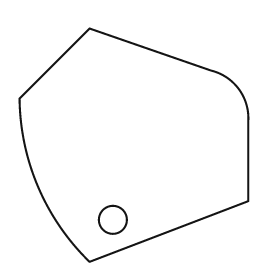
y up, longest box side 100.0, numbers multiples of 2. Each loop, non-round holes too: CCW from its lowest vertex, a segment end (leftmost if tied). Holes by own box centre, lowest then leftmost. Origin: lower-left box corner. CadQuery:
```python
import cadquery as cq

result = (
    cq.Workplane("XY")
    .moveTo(30.0, 0.0)
    .lineTo(98.0, 26.0)
    .lineTo(98.0, 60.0)
    .threePointArc((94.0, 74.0), (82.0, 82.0))
    .lineTo(30.0, 100.0)
    .lineTo(0.0, 70.0)
    .threePointArc((8.0, 32.0), (30.0, 0.0))
    .close()
    .moveTo(40.0, 18.0)
    .circle(6.0)
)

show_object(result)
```